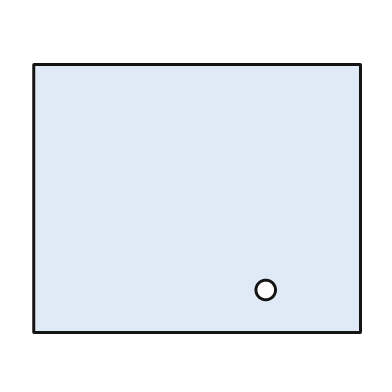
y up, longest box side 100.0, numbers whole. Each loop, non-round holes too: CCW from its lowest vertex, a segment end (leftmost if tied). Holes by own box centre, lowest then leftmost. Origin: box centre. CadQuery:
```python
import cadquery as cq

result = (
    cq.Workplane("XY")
    .moveTo(-50.0, -41.0)
    .lineTo(50.0, -41.0)
    .lineTo(50.0, 41.0)
    .lineTo(-50.0, 41.0)
    .close()
    .moveTo(21.0, -28.0)
    .circle(3.0)
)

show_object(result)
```